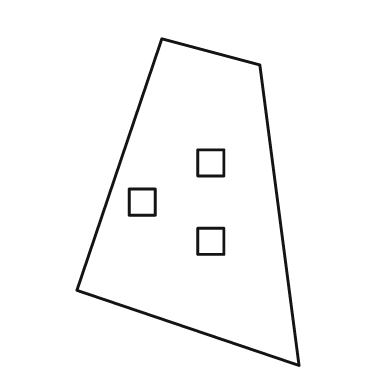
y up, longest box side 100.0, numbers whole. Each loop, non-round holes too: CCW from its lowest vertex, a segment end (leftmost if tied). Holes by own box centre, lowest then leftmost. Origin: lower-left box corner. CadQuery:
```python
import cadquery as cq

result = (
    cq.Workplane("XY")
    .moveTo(68.0, 0.0)
    .lineTo(56.0, 92.0)
    .lineTo(26.0, 100.0)
    .lineTo(0.0, 23.0)
    .close()
    .moveTo(37.0, 34.0)
    .lineTo(45.0, 34.0)
    .lineTo(45.0, 42.0)
    .lineTo(37.0, 42.0)
    .close()
    .moveTo(16.0, 46.0)
    .lineTo(24.0, 46.0)
    .lineTo(24.0, 54.0)
    .lineTo(16.0, 54.0)
    .close()
    .moveTo(37.0, 58.0)
    .lineTo(45.0, 58.0)
    .lineTo(45.0, 66.0)
    .lineTo(37.0, 66.0)
    .close()
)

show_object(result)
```